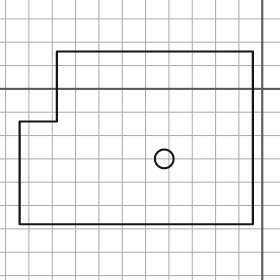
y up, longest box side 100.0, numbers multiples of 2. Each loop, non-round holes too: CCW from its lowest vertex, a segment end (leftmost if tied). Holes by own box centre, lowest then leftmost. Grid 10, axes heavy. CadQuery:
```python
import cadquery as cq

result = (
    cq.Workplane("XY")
    .moveTo(-104.0, -58.0)
    .lineTo(-4.0, -58.0)
    .lineTo(-4.0, 16.0)
    .lineTo(-88.0, 16.0)
    .lineTo(-88.0, -14.0)
    .lineTo(-104.0, -14.0)
    .close()
    .moveTo(-42.0, -30.0)
    .circle(4.0)
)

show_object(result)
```